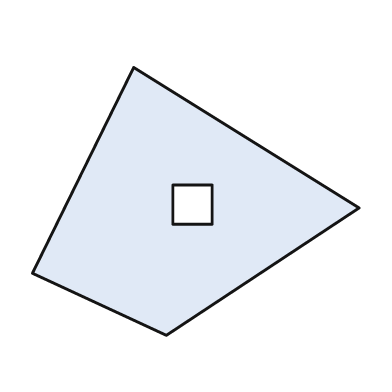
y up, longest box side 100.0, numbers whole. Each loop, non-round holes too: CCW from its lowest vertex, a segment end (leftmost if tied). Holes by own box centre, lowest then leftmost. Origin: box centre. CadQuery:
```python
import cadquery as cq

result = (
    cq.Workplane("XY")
    .moveTo(-9.0, -41.0)
    .lineTo(50.0, -2.0)
    .lineTo(-19.0, 41.0)
    .lineTo(-50.0, -22.0)
    .close()
    .moveTo(-7.0, -7.0)
    .lineTo(5.0, -7.0)
    .lineTo(5.0, 5.0)
    .lineTo(-7.0, 5.0)
    .close()
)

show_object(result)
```